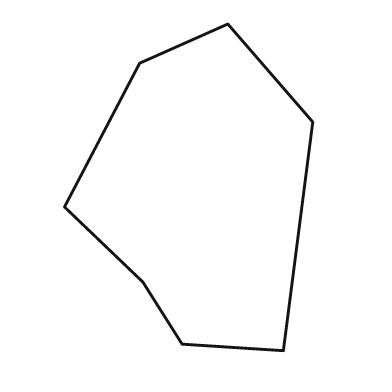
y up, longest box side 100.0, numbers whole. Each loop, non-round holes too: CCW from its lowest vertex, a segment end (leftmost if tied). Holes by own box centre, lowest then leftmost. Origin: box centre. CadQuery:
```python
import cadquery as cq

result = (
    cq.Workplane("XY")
    .moveTo(29.0, -50.0)
    .lineTo(38.0, 20.0)
    .lineTo(12.0, 50.0)
    .lineTo(-15.0, 38.0)
    .lineTo(-38.0, -6.0)
    .lineTo(-14.0, -29.0)
    .lineTo(-2.0, -48.0)
    .close()
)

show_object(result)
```